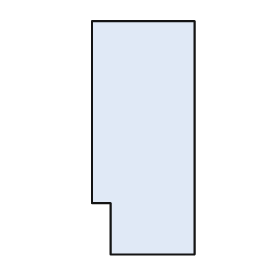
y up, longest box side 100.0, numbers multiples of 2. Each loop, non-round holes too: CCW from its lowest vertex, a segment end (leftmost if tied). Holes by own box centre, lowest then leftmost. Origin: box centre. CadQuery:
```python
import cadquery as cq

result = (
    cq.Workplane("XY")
    .moveTo(-14.0, -50.0)
    .lineTo(22.0, -50.0)
    .lineTo(22.0, 50.0)
    .lineTo(-22.0, 50.0)
    .lineTo(-22.0, -28.0)
    .lineTo(-14.0, -28.0)
    .close()
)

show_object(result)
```